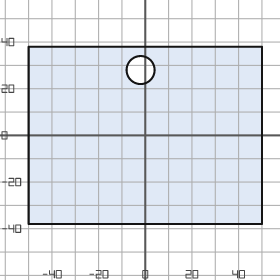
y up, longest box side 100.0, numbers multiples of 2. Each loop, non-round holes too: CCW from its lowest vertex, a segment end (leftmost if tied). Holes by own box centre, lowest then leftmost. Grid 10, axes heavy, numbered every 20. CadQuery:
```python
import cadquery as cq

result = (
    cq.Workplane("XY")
    .moveTo(-50.0, -38.0)
    .lineTo(50.0, -38.0)
    .lineTo(50.0, 38.0)
    .lineTo(-50.0, 38.0)
    .close()
    .moveTo(-2.0, 28.0)
    .circle(6.0)
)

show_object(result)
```